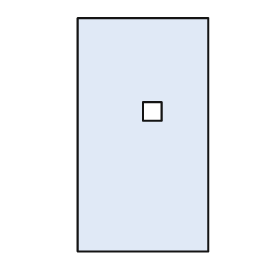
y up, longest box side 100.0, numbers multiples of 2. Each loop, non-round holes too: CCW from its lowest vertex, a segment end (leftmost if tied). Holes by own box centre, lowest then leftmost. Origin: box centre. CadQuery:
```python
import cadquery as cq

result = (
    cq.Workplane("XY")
    .moveTo(-28.0, -50.0)
    .lineTo(28.0, -50.0)
    .lineTo(28.0, 50.0)
    .lineTo(-28.0, 50.0)
    .close()
    .moveTo(0.0, 6.0)
    .lineTo(8.0, 6.0)
    .lineTo(8.0, 14.0)
    .lineTo(0.0, 14.0)
    .close()
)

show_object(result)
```